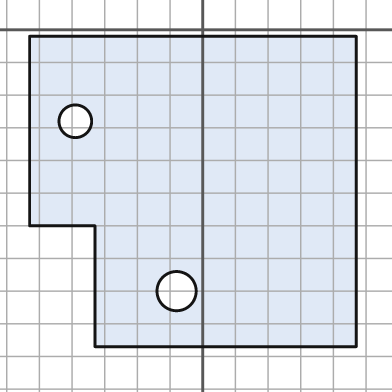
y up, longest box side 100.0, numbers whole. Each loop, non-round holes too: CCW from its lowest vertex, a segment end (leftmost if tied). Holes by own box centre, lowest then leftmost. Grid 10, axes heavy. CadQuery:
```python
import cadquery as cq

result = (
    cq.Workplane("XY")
    .moveTo(-33.0, -97.0)
    .lineTo(47.0, -97.0)
    .lineTo(47.0, -2.0)
    .lineTo(-53.0, -2.0)
    .lineTo(-53.0, -60.0)
    .lineTo(-33.0, -60.0)
    .close()
    .moveTo(-8.0, -80.0)
    .circle(6.0)
    .moveTo(-39.0, -28.0)
    .circle(5.0)
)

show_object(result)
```